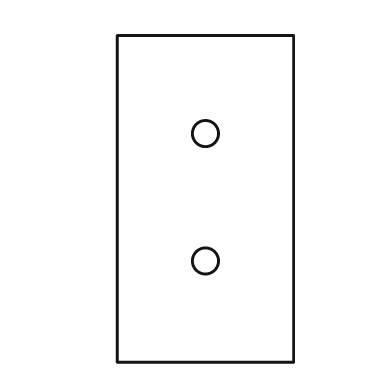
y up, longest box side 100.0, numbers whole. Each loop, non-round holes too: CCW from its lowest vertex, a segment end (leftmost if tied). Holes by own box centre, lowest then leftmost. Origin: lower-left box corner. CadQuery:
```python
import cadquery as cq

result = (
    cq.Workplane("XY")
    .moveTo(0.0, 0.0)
    .lineTo(54.0, 0.0)
    .lineTo(54.0, 100.0)
    .lineTo(0.0, 100.0)
    .close()
    .moveTo(27.0, 31.0)
    .circle(4.0)
    .moveTo(27.0, 70.0)
    .circle(4.0)
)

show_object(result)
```